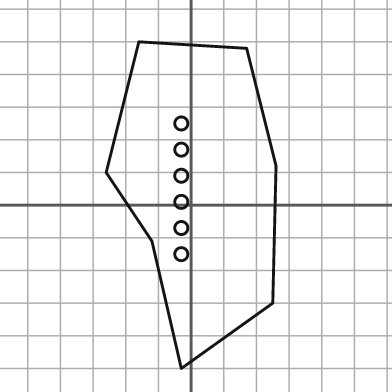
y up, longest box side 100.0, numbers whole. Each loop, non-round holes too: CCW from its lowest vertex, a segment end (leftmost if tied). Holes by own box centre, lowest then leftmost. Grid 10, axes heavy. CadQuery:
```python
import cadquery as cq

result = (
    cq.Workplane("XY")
    .moveTo(-3.0, -50.0)
    .lineTo(25.0, -30.0)
    .lineTo(26.0, 12.0)
    .lineTo(17.0, 48.0)
    .lineTo(-16.0, 50.0)
    .lineTo(-26.0, 10.0)
    .lineTo(-12.0, -11.0)
    .close()
    .moveTo(-3.0, -15.0)
    .circle(2.0)
    .moveTo(-3.0, -7.0)
    .circle(2.0)
    .moveTo(-3.0, 1.0)
    .circle(2.0)
    .moveTo(-3.0, 9.0)
    .circle(2.0)
    .moveTo(-3.0, 17.0)
    .circle(2.0)
    .moveTo(-3.0, 25.0)
    .circle(2.0)
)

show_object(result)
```